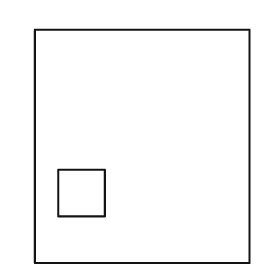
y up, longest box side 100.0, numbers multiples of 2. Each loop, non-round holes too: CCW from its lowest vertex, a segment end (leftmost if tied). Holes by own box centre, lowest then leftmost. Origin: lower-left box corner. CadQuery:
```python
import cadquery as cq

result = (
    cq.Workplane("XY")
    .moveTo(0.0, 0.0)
    .lineTo(92.0, 0.0)
    .lineTo(92.0, 100.0)
    .lineTo(0.0, 100.0)
    .close()
    .moveTo(10.0, 20.0)
    .lineTo(30.0, 20.0)
    .lineTo(30.0, 40.0)
    .lineTo(10.0, 40.0)
    .close()
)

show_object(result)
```